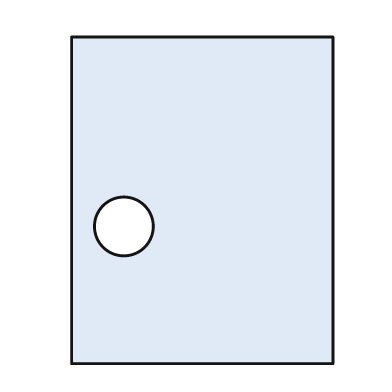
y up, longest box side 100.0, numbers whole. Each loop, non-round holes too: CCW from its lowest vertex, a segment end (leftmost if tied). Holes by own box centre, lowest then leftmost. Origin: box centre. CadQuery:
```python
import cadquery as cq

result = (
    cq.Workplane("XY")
    .moveTo(-40.0, -50.0)
    .lineTo(40.0, -50.0)
    .lineTo(40.0, 50.0)
    .lineTo(-40.0, 50.0)
    .close()
    .moveTo(-24.0, -8.0)
    .circle(9.0)
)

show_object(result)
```